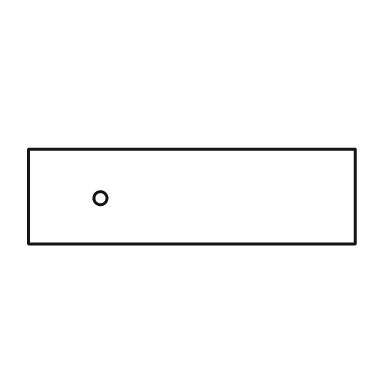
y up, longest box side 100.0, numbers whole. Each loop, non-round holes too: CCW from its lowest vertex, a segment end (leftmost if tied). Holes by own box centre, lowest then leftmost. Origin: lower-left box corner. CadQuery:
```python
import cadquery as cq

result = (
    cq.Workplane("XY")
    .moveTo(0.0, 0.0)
    .lineTo(100.0, 0.0)
    .lineTo(100.0, 29.0)
    .lineTo(0.0, 29.0)
    .close()
    .moveTo(22.0, 14.0)
    .circle(2.0)
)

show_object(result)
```